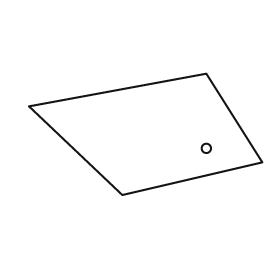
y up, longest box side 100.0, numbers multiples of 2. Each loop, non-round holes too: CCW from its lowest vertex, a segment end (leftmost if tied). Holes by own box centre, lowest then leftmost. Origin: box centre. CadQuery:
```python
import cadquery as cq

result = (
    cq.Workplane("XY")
    .moveTo(-10.0, -26.0)
    .lineTo(50.0, -12.0)
    .lineTo(26.0, 26.0)
    .lineTo(-50.0, 12.0)
    .close()
    .moveTo(26.0, -6.0)
    .circle(2.0)
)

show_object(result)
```